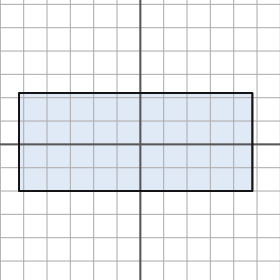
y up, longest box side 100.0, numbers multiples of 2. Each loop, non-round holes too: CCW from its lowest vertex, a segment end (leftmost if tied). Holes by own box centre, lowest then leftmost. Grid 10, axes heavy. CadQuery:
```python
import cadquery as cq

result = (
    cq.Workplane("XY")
    .moveTo(-52.0, -20.0)
    .lineTo(48.0, -20.0)
    .lineTo(48.0, 22.0)
    .lineTo(-52.0, 22.0)
    .close()
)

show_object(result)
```